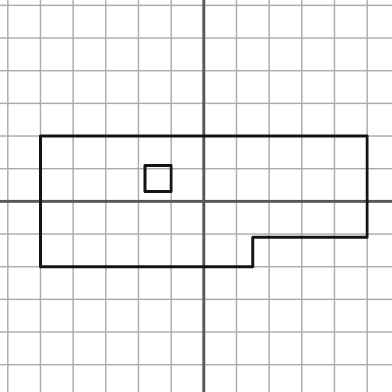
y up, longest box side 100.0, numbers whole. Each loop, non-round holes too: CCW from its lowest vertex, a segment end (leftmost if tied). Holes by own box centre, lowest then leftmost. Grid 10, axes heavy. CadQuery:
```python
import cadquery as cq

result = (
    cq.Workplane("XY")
    .moveTo(-50.0, -20.0)
    .lineTo(15.0, -20.0)
    .lineTo(15.0, -11.0)
    .lineTo(50.0, -11.0)
    .lineTo(50.0, 20.0)
    .lineTo(-50.0, 20.0)
    .close()
    .moveTo(-18.0, 3.0)
    .lineTo(-10.0, 3.0)
    .lineTo(-10.0, 11.0)
    .lineTo(-18.0, 11.0)
    .close()
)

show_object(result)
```